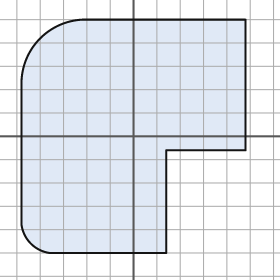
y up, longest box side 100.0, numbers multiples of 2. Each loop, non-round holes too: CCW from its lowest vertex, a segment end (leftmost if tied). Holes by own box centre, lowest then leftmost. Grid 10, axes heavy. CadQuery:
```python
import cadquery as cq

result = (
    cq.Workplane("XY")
    .moveTo(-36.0, -50.0)
    .lineTo(14.0, -50.0)
    .lineTo(14.0, -6.0)
    .lineTo(48.0, -6.0)
    .lineTo(48.0, 50.0)
    .lineTo(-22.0, 50.0)
    .threePointArc((-40.0, 42.0), (-48.0, 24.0))
    .lineTo(-48.0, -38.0)
    .threePointArc((-44.0, -46.0), (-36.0, -50.0))
    .close()
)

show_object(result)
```